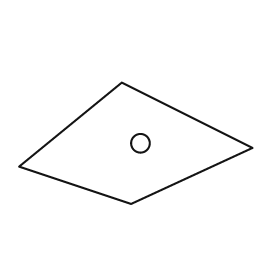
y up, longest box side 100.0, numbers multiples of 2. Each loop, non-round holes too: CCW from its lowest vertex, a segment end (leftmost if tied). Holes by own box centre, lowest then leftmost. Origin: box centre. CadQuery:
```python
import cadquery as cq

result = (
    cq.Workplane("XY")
    .moveTo(-2.0, -26.0)
    .lineTo(50.0, -2.0)
    .lineTo(-6.0, 26.0)
    .lineTo(-50.0, -10.0)
    .close()
    .moveTo(2.0, 0.0)
    .circle(4.0)
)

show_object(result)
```